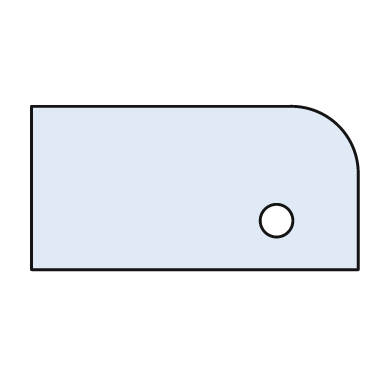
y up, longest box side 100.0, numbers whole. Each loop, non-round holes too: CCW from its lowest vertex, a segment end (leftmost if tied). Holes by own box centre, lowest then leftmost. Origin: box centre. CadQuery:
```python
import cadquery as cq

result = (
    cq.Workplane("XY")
    .moveTo(-50.0, -25.0)
    .lineTo(50.0, -25.0)
    .lineTo(50.0, 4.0)
    .threePointArc((44.0, 19.0), (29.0, 25.0))
    .lineTo(-50.0, 25.0)
    .close()
    .moveTo(25.0, -10.0)
    .circle(5.0)
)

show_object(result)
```